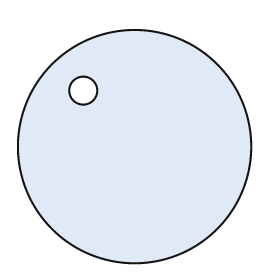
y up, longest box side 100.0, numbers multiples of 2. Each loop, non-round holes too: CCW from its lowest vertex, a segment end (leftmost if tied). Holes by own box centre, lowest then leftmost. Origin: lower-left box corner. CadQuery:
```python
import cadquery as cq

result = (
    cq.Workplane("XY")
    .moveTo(50.0, 50.0)
    .circle(50.0)
    .moveTo(28.0, 74.0)
    .circle(6.0)
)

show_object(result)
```